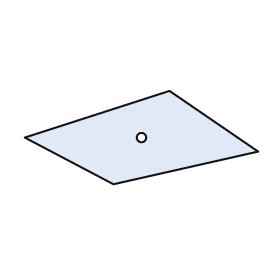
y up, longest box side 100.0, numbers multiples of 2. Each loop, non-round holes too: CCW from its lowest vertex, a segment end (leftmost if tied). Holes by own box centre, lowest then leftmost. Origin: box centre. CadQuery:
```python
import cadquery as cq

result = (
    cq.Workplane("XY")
    .moveTo(-12.0, -20.0)
    .lineTo(50.0, -6.0)
    .lineTo(12.0, 20.0)
    .lineTo(-50.0, 0.0)
    .close()
    .moveTo(0.0, 0.0)
    .circle(2.0)
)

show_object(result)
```